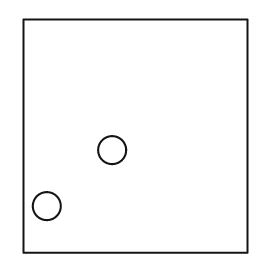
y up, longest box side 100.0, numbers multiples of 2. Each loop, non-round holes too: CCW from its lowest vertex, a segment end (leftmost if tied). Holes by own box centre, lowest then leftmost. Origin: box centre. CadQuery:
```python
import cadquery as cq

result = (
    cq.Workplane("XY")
    .moveTo(-48.0, -50.0)
    .lineTo(48.0, -50.0)
    .lineTo(48.0, 50.0)
    .lineTo(-48.0, 50.0)
    .close()
    .moveTo(-38.0, -30.0)
    .circle(6.0)
    .moveTo(-10.0, -6.0)
    .circle(6.0)
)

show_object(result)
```